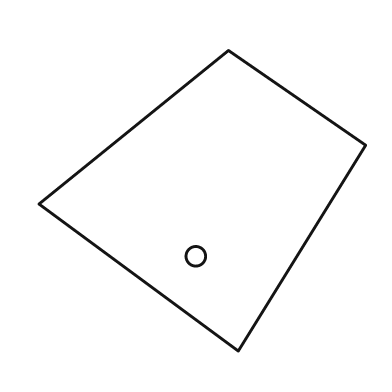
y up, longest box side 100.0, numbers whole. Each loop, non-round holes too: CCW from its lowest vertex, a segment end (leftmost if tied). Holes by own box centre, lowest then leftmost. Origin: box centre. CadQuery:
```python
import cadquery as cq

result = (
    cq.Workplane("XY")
    .moveTo(11.0, -46.0)
    .lineTo(50.0, 17.0)
    .lineTo(8.0, 46.0)
    .lineTo(-50.0, -1.0)
    .close()
    .moveTo(-2.0, -17.0)
    .circle(3.0)
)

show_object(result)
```